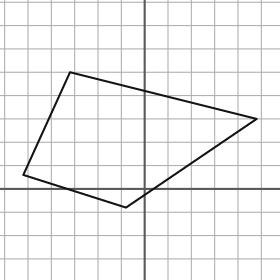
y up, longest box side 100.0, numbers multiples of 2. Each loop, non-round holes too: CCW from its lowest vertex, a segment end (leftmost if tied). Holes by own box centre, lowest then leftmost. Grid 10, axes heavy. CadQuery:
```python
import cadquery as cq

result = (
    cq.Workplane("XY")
    .moveTo(-8.0, -8.0)
    .lineTo(48.0, 30.0)
    .lineTo(-32.0, 50.0)
    .lineTo(-52.0, 6.0)
    .close()
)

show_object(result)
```